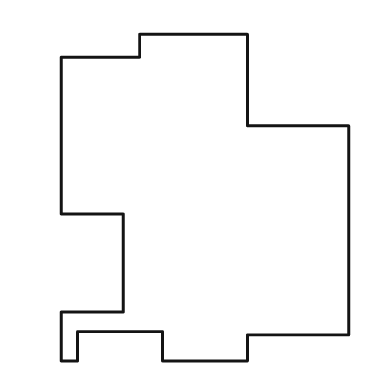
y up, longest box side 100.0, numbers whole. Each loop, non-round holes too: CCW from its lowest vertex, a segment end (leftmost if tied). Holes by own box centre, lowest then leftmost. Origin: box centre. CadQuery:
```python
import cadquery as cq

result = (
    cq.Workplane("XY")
    .moveTo(-44.0, -50.0)
    .lineTo(-39.0, -50.0)
    .lineTo(-39.0, -41.0)
    .lineTo(-13.0, -41.0)
    .lineTo(-13.0, -50.0)
    .lineTo(13.0, -50.0)
    .lineTo(13.0, -42.0)
    .lineTo(44.0, -42.0)
    .lineTo(44.0, 22.0)
    .lineTo(13.0, 22.0)
    .lineTo(13.0, 50.0)
    .lineTo(-20.0, 50.0)
    .lineTo(-20.0, 43.0)
    .lineTo(-44.0, 43.0)
    .lineTo(-44.0, -5.0)
    .lineTo(-25.0, -5.0)
    .lineTo(-25.0, -35.0)
    .lineTo(-44.0, -35.0)
    .close()
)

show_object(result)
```